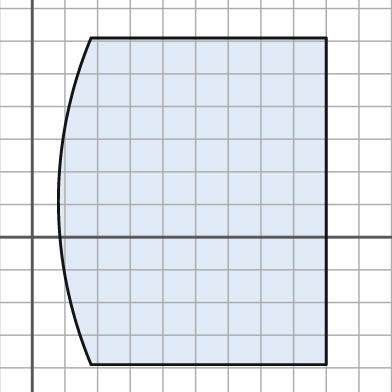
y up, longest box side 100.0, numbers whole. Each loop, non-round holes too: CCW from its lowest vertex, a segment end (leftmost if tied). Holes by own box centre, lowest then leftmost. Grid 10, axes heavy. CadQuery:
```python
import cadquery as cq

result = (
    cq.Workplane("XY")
    .moveTo(18.0, -39.0)
    .lineTo(90.0, -39.0)
    .lineTo(90.0, 61.0)
    .lineTo(18.0, 61.0)
    .threePointArc((8.0, 11.0), (18.0, -39.0))
    .close()
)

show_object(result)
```